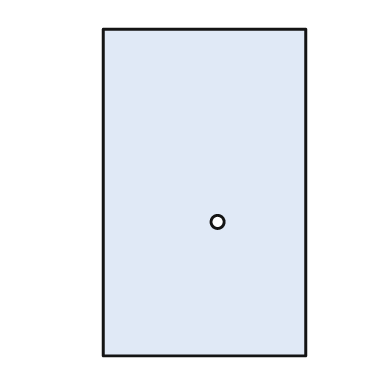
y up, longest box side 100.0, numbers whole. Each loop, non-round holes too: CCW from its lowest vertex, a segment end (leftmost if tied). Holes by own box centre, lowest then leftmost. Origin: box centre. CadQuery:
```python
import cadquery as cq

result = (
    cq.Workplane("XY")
    .moveTo(-31.0, -50.0)
    .lineTo(31.0, -50.0)
    .lineTo(31.0, 50.0)
    .lineTo(-31.0, 50.0)
    .close()
    .moveTo(4.0, -9.0)
    .circle(2.0)
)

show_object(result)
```